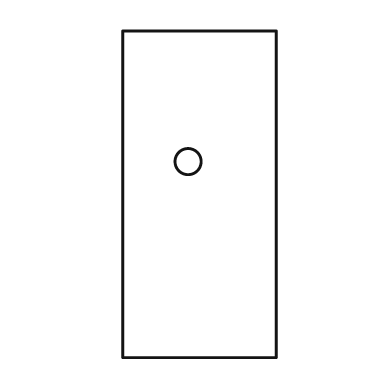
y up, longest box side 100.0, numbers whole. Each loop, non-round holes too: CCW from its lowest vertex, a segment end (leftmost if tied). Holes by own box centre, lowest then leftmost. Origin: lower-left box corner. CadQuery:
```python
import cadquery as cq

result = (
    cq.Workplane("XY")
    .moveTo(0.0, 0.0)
    .lineTo(47.0, 0.0)
    .lineTo(47.0, 100.0)
    .lineTo(0.0, 100.0)
    .close()
    .moveTo(20.0, 60.0)
    .circle(4.0)
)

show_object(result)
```